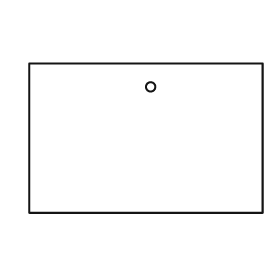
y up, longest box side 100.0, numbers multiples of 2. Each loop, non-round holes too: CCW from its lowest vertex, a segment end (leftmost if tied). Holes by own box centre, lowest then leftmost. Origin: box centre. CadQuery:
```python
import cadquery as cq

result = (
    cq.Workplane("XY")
    .moveTo(-50.0, -32.0)
    .lineTo(50.0, -32.0)
    .lineTo(50.0, 32.0)
    .lineTo(-50.0, 32.0)
    .close()
    .moveTo(2.0, 22.0)
    .circle(2.0)
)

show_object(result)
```